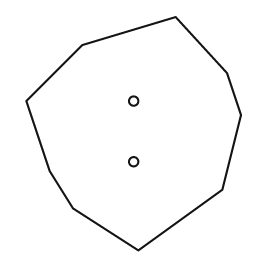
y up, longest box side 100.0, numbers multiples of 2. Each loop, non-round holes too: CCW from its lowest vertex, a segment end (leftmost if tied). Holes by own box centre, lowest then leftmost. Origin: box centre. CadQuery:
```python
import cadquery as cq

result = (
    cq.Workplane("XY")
    .moveTo(2.0, -50.0)
    .lineTo(38.0, -24.0)
    .lineTo(46.0, 8.0)
    .lineTo(40.0, 26.0)
    .lineTo(18.0, 50.0)
    .lineTo(-22.0, 38.0)
    .lineTo(-46.0, 14.0)
    .lineTo(-36.0, -16.0)
    .lineTo(-26.0, -32.0)
    .close()
    .moveTo(0.0, -12.0)
    .circle(2.0)
    .moveTo(0.0, 14.0)
    .circle(2.0)
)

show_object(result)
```